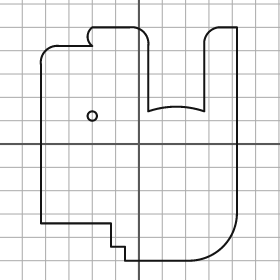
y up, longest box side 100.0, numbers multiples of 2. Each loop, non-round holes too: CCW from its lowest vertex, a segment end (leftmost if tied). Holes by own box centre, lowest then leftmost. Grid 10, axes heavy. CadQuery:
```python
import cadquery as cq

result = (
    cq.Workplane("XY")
    .moveTo(-6.0, -50.0)
    .lineTo(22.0, -50.0)
    .threePointArc((36.0, -44.0), (42.0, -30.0))
    .lineTo(42.0, 50.0)
    .lineTo(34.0, 50.0)
    .threePointArc((30.0, 48.0), (28.0, 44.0))
    .lineTo(28.0, 14.0)
    .threePointArc((16.0, 16.0), (4.0, 14.0))
    .lineTo(4.0, 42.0)
    .threePointArc((2.0, 48.0), (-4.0, 50.0))
    .lineTo(-20.0, 50.0)
    .threePointArc((-22.0, 46.0), (-20.0, 42.0))
    .lineTo(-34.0, 42.0)
    .threePointArc((-40.0, 40.0), (-42.0, 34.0))
    .lineTo(-42.0, -34.0)
    .lineTo(-12.0, -34.0)
    .lineTo(-12.0, -44.0)
    .lineTo(-6.0, -44.0)
    .close()
    .moveTo(-20.0, 12.0)
    .circle(2.0)
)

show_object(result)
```